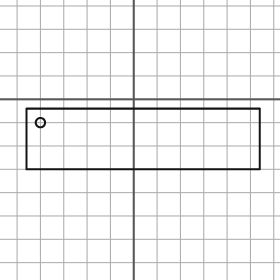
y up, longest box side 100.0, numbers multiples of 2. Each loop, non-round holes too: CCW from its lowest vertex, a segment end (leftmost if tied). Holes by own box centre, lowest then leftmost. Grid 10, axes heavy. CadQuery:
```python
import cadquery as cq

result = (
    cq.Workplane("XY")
    .moveTo(-46.0, -30.0)
    .lineTo(54.0, -30.0)
    .lineTo(54.0, -4.0)
    .lineTo(-46.0, -4.0)
    .close()
    .moveTo(-40.0, -10.0)
    .circle(2.0)
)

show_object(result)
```